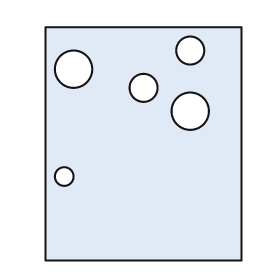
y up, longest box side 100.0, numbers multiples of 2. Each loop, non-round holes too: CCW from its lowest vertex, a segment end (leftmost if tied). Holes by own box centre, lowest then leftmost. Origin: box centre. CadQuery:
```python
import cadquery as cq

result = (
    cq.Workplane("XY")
    .moveTo(-42.0, -50.0)
    .lineTo(42.0, -50.0)
    .lineTo(42.0, 50.0)
    .lineTo(-42.0, 50.0)
    .close()
    .moveTo(-34.0, -14.0)
    .circle(4.0)
    .moveTo(20.0, 14.0)
    .circle(8.0)
    .moveTo(0.0, 24.0)
    .circle(6.0)
    .moveTo(-30.0, 32.0)
    .circle(8.0)
    .moveTo(20.0, 40.0)
    .circle(6.0)
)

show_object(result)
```